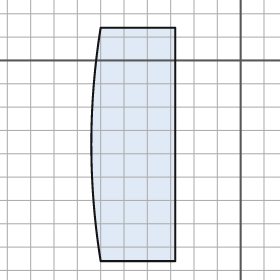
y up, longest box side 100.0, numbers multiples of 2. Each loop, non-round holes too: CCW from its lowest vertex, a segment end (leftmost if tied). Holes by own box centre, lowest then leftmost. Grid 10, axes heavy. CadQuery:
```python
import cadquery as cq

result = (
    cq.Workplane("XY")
    .moveTo(-60.0, -86.0)
    .lineTo(-28.0, -86.0)
    .lineTo(-28.0, 14.0)
    .lineTo(-60.0, 14.0)
    .threePointArc((-64.0, -36.0), (-60.0, -86.0))
    .close()
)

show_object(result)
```